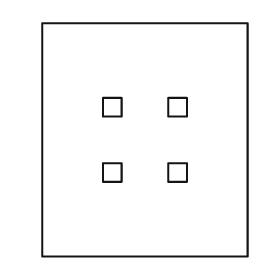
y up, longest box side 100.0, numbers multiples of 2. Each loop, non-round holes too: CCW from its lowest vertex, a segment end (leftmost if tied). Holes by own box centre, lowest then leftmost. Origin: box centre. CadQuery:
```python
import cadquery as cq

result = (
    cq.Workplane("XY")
    .moveTo(-44.0, -50.0)
    .lineTo(44.0, -50.0)
    .lineTo(44.0, 50.0)
    .lineTo(-44.0, 50.0)
    .close()
    .moveTo(-18.0, -18.0)
    .lineTo(-10.0, -18.0)
    .lineTo(-10.0, -10.0)
    .lineTo(-18.0, -10.0)
    .close()
    .moveTo(10.0, -18.0)
    .lineTo(18.0, -18.0)
    .lineTo(18.0, -10.0)
    .lineTo(10.0, -10.0)
    .close()
    .moveTo(-18.0, 10.0)
    .lineTo(-10.0, 10.0)
    .lineTo(-10.0, 18.0)
    .lineTo(-18.0, 18.0)
    .close()
    .moveTo(10.0, 10.0)
    .lineTo(18.0, 10.0)
    .lineTo(18.0, 18.0)
    .lineTo(10.0, 18.0)
    .close()
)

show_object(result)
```